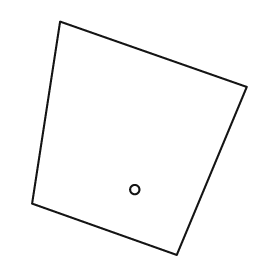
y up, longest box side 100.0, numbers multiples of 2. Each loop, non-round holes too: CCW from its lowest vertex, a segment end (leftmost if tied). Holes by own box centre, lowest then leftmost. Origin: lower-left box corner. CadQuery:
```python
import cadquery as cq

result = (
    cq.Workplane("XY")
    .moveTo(62.0, 0.0)
    .lineTo(92.0, 72.0)
    .lineTo(12.0, 100.0)
    .lineTo(0.0, 22.0)
    .close()
    .moveTo(44.0, 28.0)
    .circle(2.0)
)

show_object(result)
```